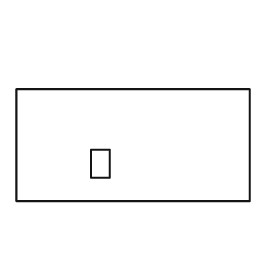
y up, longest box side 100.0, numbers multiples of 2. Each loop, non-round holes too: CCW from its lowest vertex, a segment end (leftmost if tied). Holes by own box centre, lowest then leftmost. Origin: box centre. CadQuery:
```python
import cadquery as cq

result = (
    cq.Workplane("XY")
    .moveTo(-50.0, -24.0)
    .lineTo(50.0, -24.0)
    .lineTo(50.0, 24.0)
    .lineTo(-50.0, 24.0)
    .close()
    .moveTo(-18.0, -14.0)
    .lineTo(-10.0, -14.0)
    .lineTo(-10.0, -2.0)
    .lineTo(-18.0, -2.0)
    .close()
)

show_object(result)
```